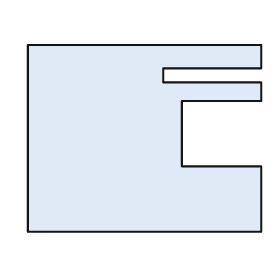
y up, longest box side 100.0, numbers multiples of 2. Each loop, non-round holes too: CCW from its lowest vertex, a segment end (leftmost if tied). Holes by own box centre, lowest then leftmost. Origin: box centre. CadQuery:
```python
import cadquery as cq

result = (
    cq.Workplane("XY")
    .moveTo(-50.0, -40.0)
    .lineTo(50.0, -40.0)
    .lineTo(50.0, -12.0)
    .lineTo(16.0, -12.0)
    .lineTo(16.0, 16.0)
    .lineTo(50.0, 16.0)
    .lineTo(50.0, 24.0)
    .lineTo(8.0, 24.0)
    .lineTo(8.0, 30.0)
    .lineTo(50.0, 30.0)
    .lineTo(50.0, 40.0)
    .lineTo(-50.0, 40.0)
    .close()
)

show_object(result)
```